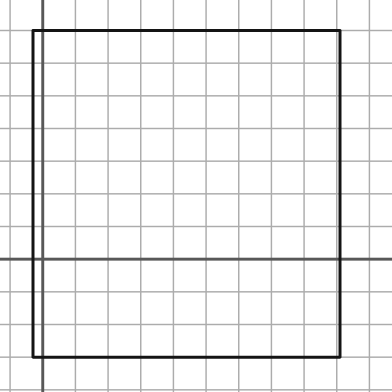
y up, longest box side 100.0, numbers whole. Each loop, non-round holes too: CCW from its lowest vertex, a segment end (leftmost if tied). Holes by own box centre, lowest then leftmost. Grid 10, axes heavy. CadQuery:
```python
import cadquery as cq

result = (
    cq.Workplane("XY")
    .moveTo(-3.0, -30.0)
    .lineTo(91.0, -30.0)
    .lineTo(91.0, 70.0)
    .lineTo(-3.0, 70.0)
    .close()
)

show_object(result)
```